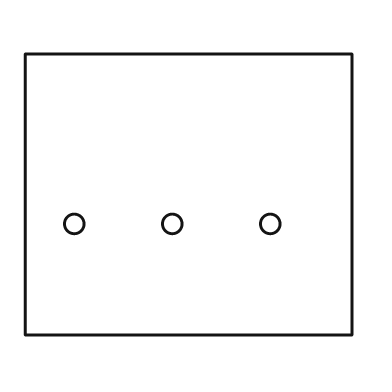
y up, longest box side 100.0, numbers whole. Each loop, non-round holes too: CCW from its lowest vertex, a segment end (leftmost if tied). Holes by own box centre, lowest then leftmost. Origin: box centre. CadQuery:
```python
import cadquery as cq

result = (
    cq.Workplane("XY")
    .moveTo(-50.0, -43.0)
    .lineTo(50.0, -43.0)
    .lineTo(50.0, 43.0)
    .lineTo(-50.0, 43.0)
    .close()
    .moveTo(-35.0, -9.0)
    .circle(3.0)
    .moveTo(-5.0, -9.0)
    .circle(3.0)
    .moveTo(25.0, -9.0)
    .circle(3.0)
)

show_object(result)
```